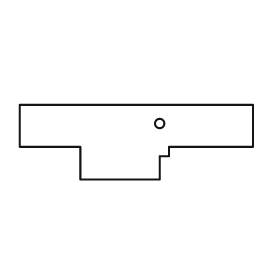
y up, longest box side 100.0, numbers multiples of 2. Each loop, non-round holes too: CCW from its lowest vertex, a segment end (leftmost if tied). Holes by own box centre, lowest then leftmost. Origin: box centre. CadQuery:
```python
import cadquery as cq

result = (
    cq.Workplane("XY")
    .moveTo(-24.0, -16.0)
    .lineTo(10.0, -16.0)
    .lineTo(10.0, -6.0)
    .lineTo(14.0, -6.0)
    .lineTo(14.0, -2.0)
    .lineTo(50.0, -2.0)
    .lineTo(50.0, 16.0)
    .lineTo(-50.0, 16.0)
    .lineTo(-50.0, -2.0)
    .lineTo(-24.0, -2.0)
    .close()
    .moveTo(10.0, 8.0)
    .circle(2.0)
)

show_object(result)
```